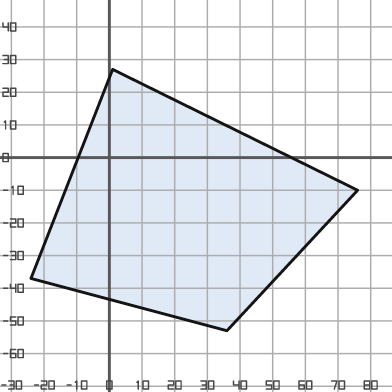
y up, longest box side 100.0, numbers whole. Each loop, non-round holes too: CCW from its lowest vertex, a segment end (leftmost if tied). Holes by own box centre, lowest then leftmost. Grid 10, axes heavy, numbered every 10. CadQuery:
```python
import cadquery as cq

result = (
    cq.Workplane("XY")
    .moveTo(36.0, -53.0)
    .lineTo(76.0, -10.0)
    .lineTo(1.0, 27.0)
    .lineTo(-24.0, -37.0)
    .close()
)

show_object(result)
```